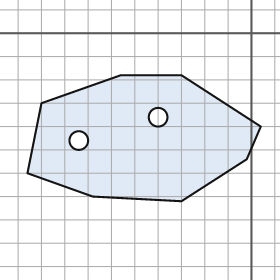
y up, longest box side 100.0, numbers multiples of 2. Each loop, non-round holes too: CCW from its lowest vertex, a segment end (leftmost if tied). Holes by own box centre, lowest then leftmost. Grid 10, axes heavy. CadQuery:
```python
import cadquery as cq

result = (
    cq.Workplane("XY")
    .moveTo(-30.0, -72.0)
    .lineTo(-2.0, -54.0)
    .lineTo(4.0, -40.0)
    .lineTo(-30.0, -18.0)
    .lineTo(-56.0, -18.0)
    .lineTo(-90.0, -30.0)
    .lineTo(-96.0, -60.0)
    .lineTo(-68.0, -70.0)
    .close()
    .moveTo(-74.0, -46.0)
    .circle(4.0)
    .moveTo(-40.0, -36.0)
    .circle(4.0)
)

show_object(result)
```